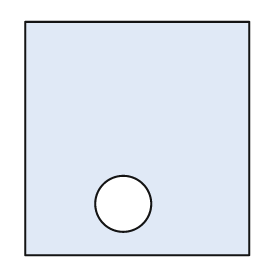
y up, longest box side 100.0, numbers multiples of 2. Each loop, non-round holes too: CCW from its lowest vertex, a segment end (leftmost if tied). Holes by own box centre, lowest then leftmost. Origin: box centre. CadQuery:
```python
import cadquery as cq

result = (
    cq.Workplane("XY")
    .moveTo(-48.0, -50.0)
    .lineTo(48.0, -50.0)
    .lineTo(48.0, 50.0)
    .lineTo(-48.0, 50.0)
    .close()
    .moveTo(-6.0, -28.0)
    .circle(12.0)
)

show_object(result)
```